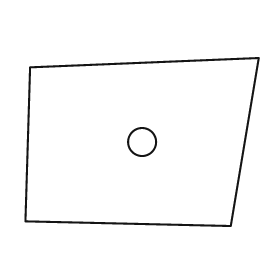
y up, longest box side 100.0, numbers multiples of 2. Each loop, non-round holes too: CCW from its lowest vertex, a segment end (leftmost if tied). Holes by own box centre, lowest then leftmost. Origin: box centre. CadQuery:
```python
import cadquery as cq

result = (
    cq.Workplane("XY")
    .moveTo(38.0, -36.0)
    .lineTo(50.0, 36.0)
    .lineTo(-48.0, 32.0)
    .lineTo(-50.0, -34.0)
    .close()
    .moveTo(0.0, 0.0)
    .circle(6.0)
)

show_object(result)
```